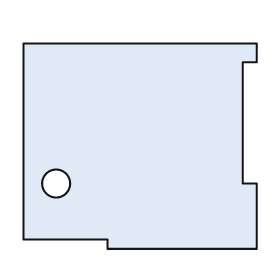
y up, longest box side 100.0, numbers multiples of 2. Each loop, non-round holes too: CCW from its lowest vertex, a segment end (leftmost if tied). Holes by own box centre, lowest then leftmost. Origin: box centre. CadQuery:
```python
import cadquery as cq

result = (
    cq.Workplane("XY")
    .moveTo(-14.0, -44.0)
    .lineTo(50.0, -44.0)
    .lineTo(50.0, -16.0)
    .lineTo(44.0, -16.0)
    .lineTo(44.0, 36.0)
    .lineTo(50.0, 36.0)
    .lineTo(50.0, 44.0)
    .lineTo(-50.0, 44.0)
    .lineTo(-50.0, -40.0)
    .lineTo(-14.0, -40.0)
    .close()
    .moveTo(-36.0, -16.0)
    .circle(6.0)
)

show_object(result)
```